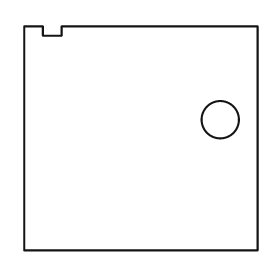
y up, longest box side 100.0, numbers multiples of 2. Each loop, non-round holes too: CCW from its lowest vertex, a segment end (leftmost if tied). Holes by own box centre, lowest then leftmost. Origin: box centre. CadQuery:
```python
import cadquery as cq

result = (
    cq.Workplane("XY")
    .moveTo(-50.0, -48.0)
    .lineTo(50.0, -48.0)
    .lineTo(50.0, 48.0)
    .lineTo(-34.0, 48.0)
    .lineTo(-34.0, 44.0)
    .lineTo(-42.0, 44.0)
    .lineTo(-42.0, 48.0)
    .lineTo(-50.0, 48.0)
    .close()
    .moveTo(34.0, 8.0)
    .circle(8.0)
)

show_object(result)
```